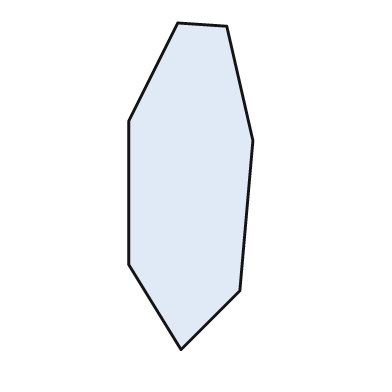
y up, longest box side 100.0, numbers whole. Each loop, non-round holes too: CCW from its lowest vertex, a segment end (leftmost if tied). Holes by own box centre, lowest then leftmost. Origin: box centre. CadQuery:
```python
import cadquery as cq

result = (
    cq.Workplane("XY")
    .moveTo(-3.0, -50.0)
    .lineTo(15.0, -32.0)
    .lineTo(19.0, 14.0)
    .lineTo(11.0, 49.0)
    .lineTo(-4.0, 50.0)
    .lineTo(-19.0, 20.0)
    .lineTo(-19.0, -24.0)
    .close()
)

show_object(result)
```